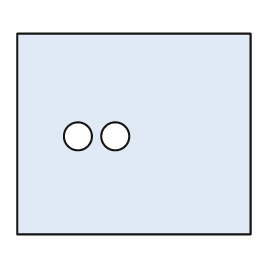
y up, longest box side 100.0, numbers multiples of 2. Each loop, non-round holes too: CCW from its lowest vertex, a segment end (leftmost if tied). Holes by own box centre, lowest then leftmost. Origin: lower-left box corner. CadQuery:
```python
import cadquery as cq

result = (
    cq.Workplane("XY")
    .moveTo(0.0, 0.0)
    .lineTo(100.0, 0.0)
    .lineTo(100.0, 86.0)
    .lineTo(0.0, 86.0)
    .close()
    .moveTo(26.0, 42.0)
    .circle(6.0)
    .moveTo(42.0, 42.0)
    .circle(6.0)
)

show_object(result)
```